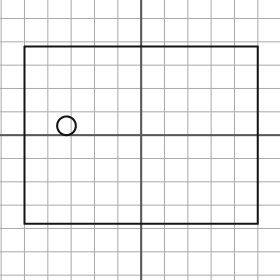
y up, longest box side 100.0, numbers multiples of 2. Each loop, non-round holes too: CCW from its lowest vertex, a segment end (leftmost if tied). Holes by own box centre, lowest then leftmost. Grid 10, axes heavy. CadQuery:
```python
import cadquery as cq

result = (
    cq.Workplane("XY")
    .moveTo(-50.0, -38.0)
    .lineTo(50.0, -38.0)
    .lineTo(50.0, 38.0)
    .lineTo(-50.0, 38.0)
    .close()
    .moveTo(-32.0, 4.0)
    .circle(4.0)
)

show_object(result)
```